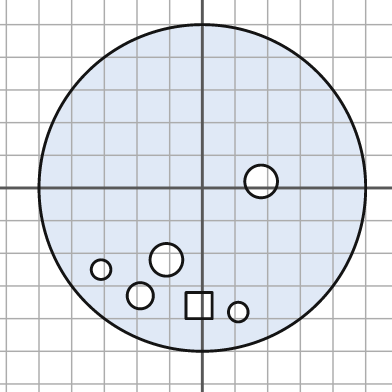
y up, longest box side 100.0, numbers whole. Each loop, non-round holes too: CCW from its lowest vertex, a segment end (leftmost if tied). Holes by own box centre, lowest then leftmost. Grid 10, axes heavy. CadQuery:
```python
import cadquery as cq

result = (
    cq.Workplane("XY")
    .moveTo(0.0, 0.0)
    .circle(50.0)
    .moveTo(11.0, -38.0)
    .circle(3.0)
    .moveTo(-5.0, -40.0)
    .lineTo(3.0, -40.0)
    .lineTo(3.0, -32.0)
    .lineTo(-5.0, -32.0)
    .close()
    .moveTo(-19.0, -33.0)
    .circle(4.0)
    .moveTo(-31.0, -25.0)
    .circle(3.0)
    .moveTo(-11.0, -22.0)
    .circle(5.0)
    .moveTo(18.0, 2.0)
    .circle(5.0)
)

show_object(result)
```